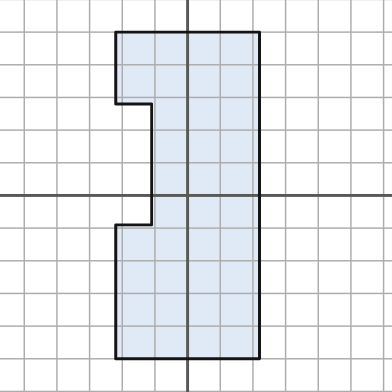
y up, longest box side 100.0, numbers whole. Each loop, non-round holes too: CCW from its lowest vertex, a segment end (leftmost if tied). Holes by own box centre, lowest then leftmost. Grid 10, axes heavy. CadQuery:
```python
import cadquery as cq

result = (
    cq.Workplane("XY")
    .moveTo(-22.0, -50.0)
    .lineTo(22.0, -50.0)
    .lineTo(22.0, 50.0)
    .lineTo(-22.0, 50.0)
    .lineTo(-22.0, 28.0)
    .lineTo(-11.0, 28.0)
    .lineTo(-11.0, -9.0)
    .lineTo(-22.0, -9.0)
    .close()
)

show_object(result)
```